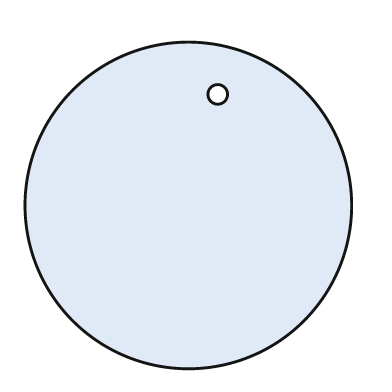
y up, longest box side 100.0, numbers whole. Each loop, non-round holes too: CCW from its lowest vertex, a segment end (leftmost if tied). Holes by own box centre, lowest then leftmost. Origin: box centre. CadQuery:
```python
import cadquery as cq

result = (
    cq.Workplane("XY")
    .moveTo(0.0, 0.0)
    .circle(50.0)
    .moveTo(9.0, 34.0)
    .circle(3.0)
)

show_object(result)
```